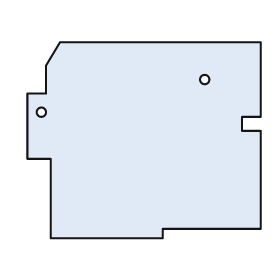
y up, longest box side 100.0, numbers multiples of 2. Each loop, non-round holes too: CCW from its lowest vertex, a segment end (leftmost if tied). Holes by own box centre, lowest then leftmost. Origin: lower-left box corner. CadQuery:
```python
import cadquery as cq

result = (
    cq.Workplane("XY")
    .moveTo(10.0, 0.0)
    .lineTo(58.0, 0.0)
    .lineTo(58.0, 4.0)
    .lineTo(100.0, 4.0)
    .lineTo(100.0, 46.0)
    .lineTo(92.0, 46.0)
    .lineTo(92.0, 52.0)
    .lineTo(100.0, 52.0)
    .lineTo(100.0, 84.0)
    .lineTo(14.0, 84.0)
    .lineTo(8.0, 74.0)
    .lineTo(8.0, 62.0)
    .lineTo(0.0, 62.0)
    .lineTo(0.0, 34.0)
    .lineTo(10.0, 34.0)
    .close()
    .moveTo(6.0, 54.0)
    .circle(2.0)
    .moveTo(76.0, 68.0)
    .circle(2.0)
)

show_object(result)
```